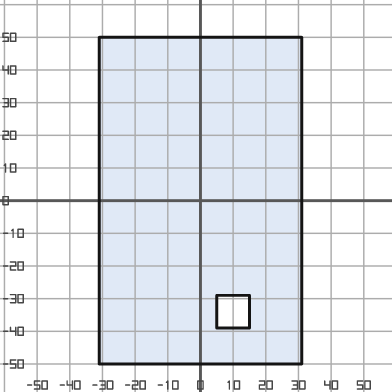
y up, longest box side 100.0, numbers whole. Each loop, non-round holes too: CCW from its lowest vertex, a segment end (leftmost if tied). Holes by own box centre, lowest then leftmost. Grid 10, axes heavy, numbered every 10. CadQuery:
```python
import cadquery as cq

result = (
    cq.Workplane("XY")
    .moveTo(-31.0, -50.0)
    .lineTo(31.0, -50.0)
    .lineTo(31.0, 50.0)
    .lineTo(-31.0, 50.0)
    .close()
    .moveTo(5.0, -39.0)
    .lineTo(15.0, -39.0)
    .lineTo(15.0, -29.0)
    .lineTo(5.0, -29.0)
    .close()
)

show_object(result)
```